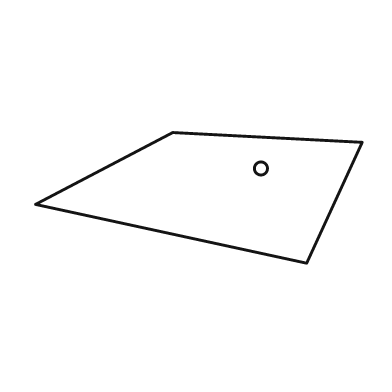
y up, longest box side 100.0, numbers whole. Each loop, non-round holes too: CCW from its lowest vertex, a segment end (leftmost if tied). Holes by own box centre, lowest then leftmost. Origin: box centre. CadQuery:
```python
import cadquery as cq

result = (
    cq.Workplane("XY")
    .moveTo(33.0, -20.0)
    .lineTo(50.0, 17.0)
    .lineTo(-8.0, 20.0)
    .lineTo(-50.0, -2.0)
    .close()
    .moveTo(19.0, 9.0)
    .circle(2.0)
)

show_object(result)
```